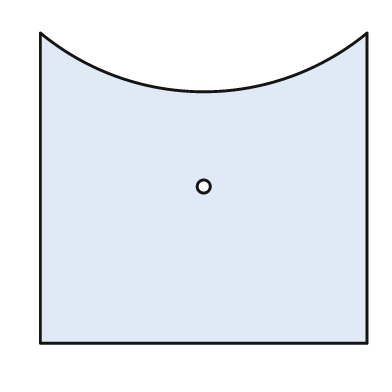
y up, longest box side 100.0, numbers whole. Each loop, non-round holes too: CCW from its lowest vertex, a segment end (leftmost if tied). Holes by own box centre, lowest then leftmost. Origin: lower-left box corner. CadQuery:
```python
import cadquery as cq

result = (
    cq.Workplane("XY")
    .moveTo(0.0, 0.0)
    .lineTo(100.0, 0.0)
    .lineTo(100.0, 95.0)
    .threePointArc((50.0, 77.0), (0.0, 95.0))
    .close()
    .moveTo(50.0, 48.0)
    .circle(2.0)
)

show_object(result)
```